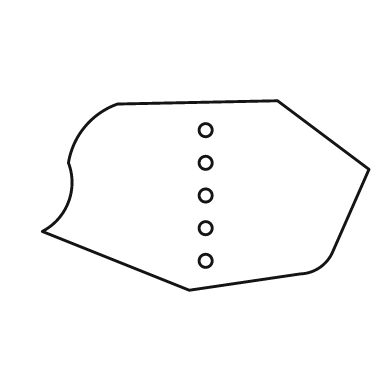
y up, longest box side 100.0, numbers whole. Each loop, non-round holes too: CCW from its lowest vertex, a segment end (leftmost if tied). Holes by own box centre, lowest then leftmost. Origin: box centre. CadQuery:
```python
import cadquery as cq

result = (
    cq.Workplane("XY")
    .moveTo(-5.0, -29.0)
    .lineTo(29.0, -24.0)
    .threePointArc((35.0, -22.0), (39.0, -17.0))
    .lineTo(50.0, 8.0)
    .lineTo(22.0, 29.0)
    .lineTo(-27.0, 28.0)
    .threePointArc((-37.0, 21.0), (-42.0, 10.0))
    .threePointArc((-42.0, -2.0), (-50.0, -11.0))
    .close()
    .moveTo(0.0, -20.0)
    .circle(2.0)
    .moveTo(0.0, -10.0)
    .circle(2.0)
    .moveTo(0.0, 0.0)
    .circle(2.0)
    .moveTo(0.0, 10.0)
    .circle(2.0)
    .moveTo(0.0, 20.0)
    .circle(2.0)
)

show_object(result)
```